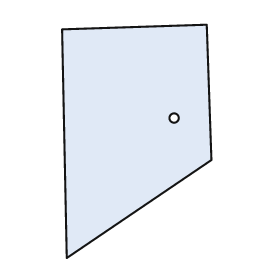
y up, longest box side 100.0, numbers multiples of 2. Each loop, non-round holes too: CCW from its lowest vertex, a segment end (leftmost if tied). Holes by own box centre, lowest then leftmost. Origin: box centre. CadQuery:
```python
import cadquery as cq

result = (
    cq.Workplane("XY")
    .moveTo(-30.0, -50.0)
    .lineTo(32.0, -8.0)
    .lineTo(30.0, 50.0)
    .lineTo(-32.0, 48.0)
    .close()
    .moveTo(16.0, 10.0)
    .circle(2.0)
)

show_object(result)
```